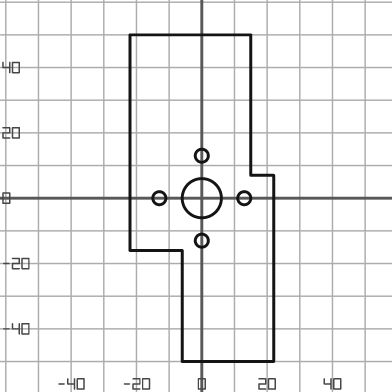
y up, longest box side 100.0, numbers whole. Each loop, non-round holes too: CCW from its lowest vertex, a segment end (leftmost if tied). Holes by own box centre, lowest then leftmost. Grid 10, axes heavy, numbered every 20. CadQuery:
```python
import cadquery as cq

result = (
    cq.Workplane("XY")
    .moveTo(-6.0, -50.0)
    .lineTo(22.0, -50.0)
    .lineTo(22.0, 7.0)
    .lineTo(15.0, 7.0)
    .lineTo(15.0, 50.0)
    .lineTo(-22.0, 50.0)
    .lineTo(-22.0, -16.0)
    .lineTo(-6.0, -16.0)
    .close()
    .moveTo(0.0, -13.0)
    .circle(2.0)
    .moveTo(-13.0, 0.0)
    .circle(2.0)
    .moveTo(0.0, 0.0)
    .circle(6.0)
    .moveTo(13.0, 0.0)
    .circle(2.0)
    .moveTo(0.0, 13.0)
    .circle(2.0)
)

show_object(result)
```